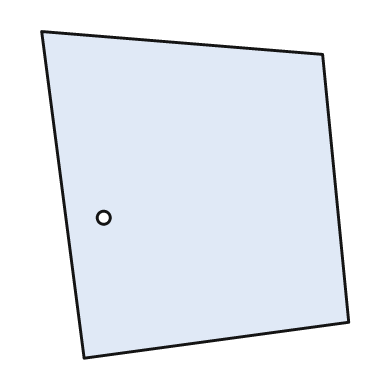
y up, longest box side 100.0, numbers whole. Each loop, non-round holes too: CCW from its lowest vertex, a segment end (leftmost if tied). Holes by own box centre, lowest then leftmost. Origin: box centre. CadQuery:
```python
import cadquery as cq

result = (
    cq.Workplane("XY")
    .moveTo(-34.0, -50.0)
    .lineTo(47.0, -39.0)
    .lineTo(39.0, 43.0)
    .lineTo(-47.0, 50.0)
    .close()
    .moveTo(-28.0, -7.0)
    .circle(2.0)
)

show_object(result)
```